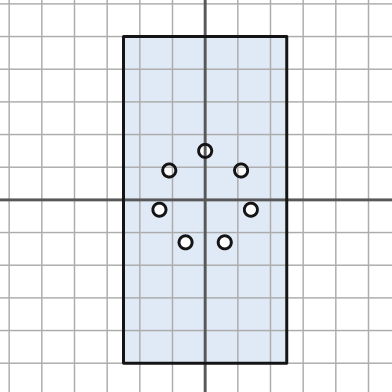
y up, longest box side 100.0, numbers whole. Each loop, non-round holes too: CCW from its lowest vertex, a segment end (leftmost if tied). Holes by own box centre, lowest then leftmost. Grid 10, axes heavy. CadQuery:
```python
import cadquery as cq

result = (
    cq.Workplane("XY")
    .moveTo(-25.0, -50.0)
    .lineTo(25.0, -50.0)
    .lineTo(25.0, 50.0)
    .lineTo(-25.0, 50.0)
    .close()
    .moveTo(-6.0, -13.0)
    .circle(2.0)
    .moveTo(6.0, -13.0)
    .circle(2.0)
    .moveTo(-14.0, -3.0)
    .circle(2.0)
    .moveTo(14.0, -3.0)
    .circle(2.0)
    .moveTo(-11.0, 9.0)
    .circle(2.0)
    .moveTo(11.0, 9.0)
    .circle(2.0)
    .moveTo(0.0, 15.0)
    .circle(2.0)
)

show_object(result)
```